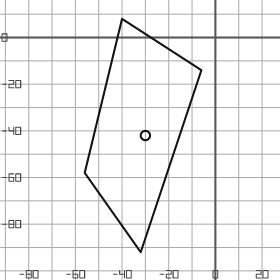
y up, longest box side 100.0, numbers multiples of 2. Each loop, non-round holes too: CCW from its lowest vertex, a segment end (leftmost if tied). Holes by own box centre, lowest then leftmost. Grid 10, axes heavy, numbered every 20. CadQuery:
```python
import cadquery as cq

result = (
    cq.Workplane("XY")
    .moveTo(-32.0, -92.0)
    .lineTo(-6.0, -14.0)
    .lineTo(-40.0, 8.0)
    .lineTo(-56.0, -58.0)
    .close()
    .moveTo(-30.0, -42.0)
    .circle(2.0)
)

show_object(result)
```